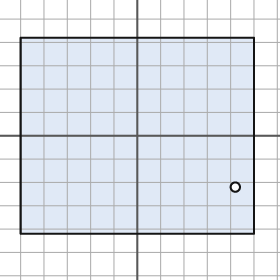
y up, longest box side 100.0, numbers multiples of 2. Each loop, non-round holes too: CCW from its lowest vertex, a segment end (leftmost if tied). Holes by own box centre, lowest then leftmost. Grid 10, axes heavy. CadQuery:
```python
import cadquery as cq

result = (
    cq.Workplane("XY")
    .moveTo(-50.0, -42.0)
    .lineTo(50.0, -42.0)
    .lineTo(50.0, 42.0)
    .lineTo(-50.0, 42.0)
    .close()
    .moveTo(42.0, -22.0)
    .circle(2.0)
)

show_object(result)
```